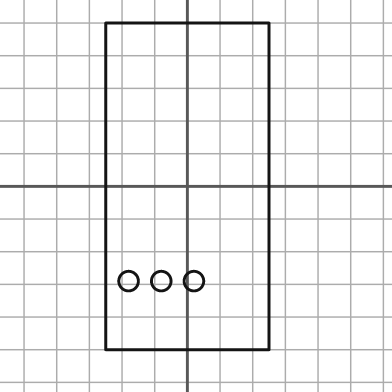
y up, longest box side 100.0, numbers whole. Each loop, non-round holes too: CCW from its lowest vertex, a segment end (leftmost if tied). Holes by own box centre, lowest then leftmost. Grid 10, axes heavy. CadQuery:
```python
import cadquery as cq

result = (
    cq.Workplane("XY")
    .moveTo(-25.0, -50.0)
    .lineTo(25.0, -50.0)
    .lineTo(25.0, 50.0)
    .lineTo(-25.0, 50.0)
    .close()
    .moveTo(-18.0, -29.0)
    .circle(3.0)
    .moveTo(-8.0, -29.0)
    .circle(3.0)
    .moveTo(2.0, -29.0)
    .circle(3.0)
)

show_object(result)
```